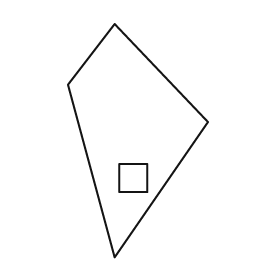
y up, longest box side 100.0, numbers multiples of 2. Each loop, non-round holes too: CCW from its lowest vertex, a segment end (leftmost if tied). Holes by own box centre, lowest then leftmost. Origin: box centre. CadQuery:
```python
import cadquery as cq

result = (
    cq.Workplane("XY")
    .moveTo(-10.0, -50.0)
    .lineTo(30.0, 8.0)
    .lineTo(-10.0, 50.0)
    .lineTo(-30.0, 24.0)
    .close()
    .moveTo(-8.0, -22.0)
    .lineTo(4.0, -22.0)
    .lineTo(4.0, -10.0)
    .lineTo(-8.0, -10.0)
    .close()
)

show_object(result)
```